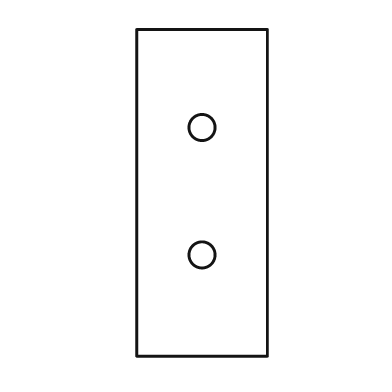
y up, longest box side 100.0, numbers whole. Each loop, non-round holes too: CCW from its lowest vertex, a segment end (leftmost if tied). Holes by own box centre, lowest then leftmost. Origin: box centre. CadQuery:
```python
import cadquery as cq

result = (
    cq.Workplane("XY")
    .moveTo(-20.0, -50.0)
    .lineTo(20.0, -50.0)
    .lineTo(20.0, 50.0)
    .lineTo(-20.0, 50.0)
    .close()
    .moveTo(0.0, -19.0)
    .circle(4.0)
    .moveTo(0.0, 20.0)
    .circle(4.0)
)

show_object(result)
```